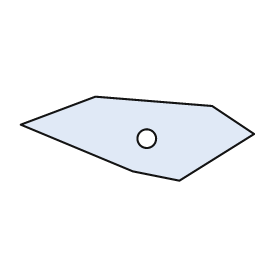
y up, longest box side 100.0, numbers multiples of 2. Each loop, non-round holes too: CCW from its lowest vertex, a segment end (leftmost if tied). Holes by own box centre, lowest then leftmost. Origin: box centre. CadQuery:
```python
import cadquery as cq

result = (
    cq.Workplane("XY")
    .moveTo(18.0, -18.0)
    .lineTo(50.0, 2.0)
    .lineTo(32.0, 14.0)
    .lineTo(-18.0, 18.0)
    .lineTo(-50.0, 6.0)
    .lineTo(-2.0, -14.0)
    .close()
    .moveTo(4.0, 0.0)
    .circle(4.0)
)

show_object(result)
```